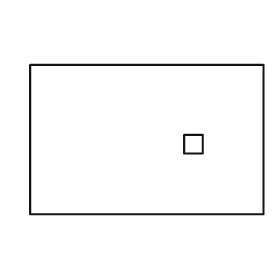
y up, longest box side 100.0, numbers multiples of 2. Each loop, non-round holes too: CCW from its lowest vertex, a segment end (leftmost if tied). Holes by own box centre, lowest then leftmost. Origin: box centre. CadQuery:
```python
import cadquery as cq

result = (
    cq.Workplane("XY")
    .moveTo(-50.0, -32.0)
    .lineTo(50.0, -32.0)
    .lineTo(50.0, 32.0)
    .lineTo(-50.0, 32.0)
    .close()
    .moveTo(16.0, -6.0)
    .lineTo(24.0, -6.0)
    .lineTo(24.0, 2.0)
    .lineTo(16.0, 2.0)
    .close()
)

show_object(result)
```